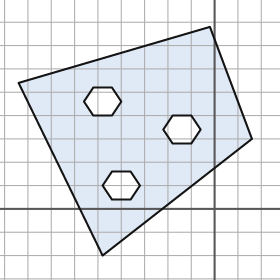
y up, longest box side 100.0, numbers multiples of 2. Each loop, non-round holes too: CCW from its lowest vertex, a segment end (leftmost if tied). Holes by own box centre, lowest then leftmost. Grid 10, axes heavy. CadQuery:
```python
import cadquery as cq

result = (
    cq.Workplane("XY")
    .moveTo(-48.0, -20.0)
    .lineTo(16.0, 30.0)
    .lineTo(-2.0, 78.0)
    .lineTo(-84.0, 54.0)
    .close()
    .moveTo(-44.0, 4.0)
    .lineTo(-36.0, 4.0)
    .lineTo(-32.0, 10.0)
    .lineTo(-36.0, 16.0)
    .lineTo(-44.0, 16.0)
    .lineTo(-48.0, 10.0)
    .close()
    .moveTo(-18.0, 28.0)
    .lineTo(-10.0, 28.0)
    .lineTo(-6.0, 34.0)
    .lineTo(-10.0, 40.0)
    .lineTo(-18.0, 40.0)
    .lineTo(-22.0, 34.0)
    .close()
    .moveTo(-52.0, 40.0)
    .lineTo(-44.0, 40.0)
    .lineTo(-40.0, 46.0)
    .lineTo(-44.0, 52.0)
    .lineTo(-52.0, 52.0)
    .lineTo(-56.0, 46.0)
    .close()
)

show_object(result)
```